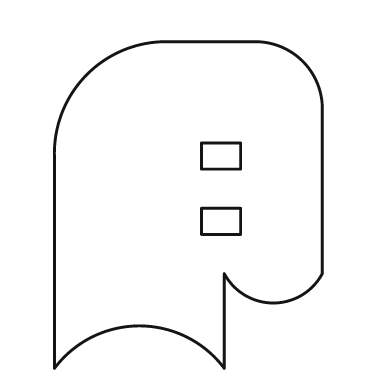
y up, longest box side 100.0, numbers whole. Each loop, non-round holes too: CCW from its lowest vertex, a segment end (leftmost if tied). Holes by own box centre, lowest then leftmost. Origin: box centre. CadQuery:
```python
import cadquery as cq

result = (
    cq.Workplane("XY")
    .moveTo(-41.0, -50.0)
    .threePointArc((-15.0, -37.0), (11.0, -50.0))
    .lineTo(11.0, -21.0)
    .threePointArc((26.0, -30.0), (41.0, -21.0))
    .lineTo(41.0, 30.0)
    .threePointArc((35.0, 44.0), (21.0, 50.0))
    .lineTo(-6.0, 50.0)
    .threePointArc((-31.0, 40.0), (-41.0, 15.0))
    .close()
    .moveTo(4.0, -9.0)
    .lineTo(16.0, -9.0)
    .lineTo(16.0, -1.0)
    .lineTo(4.0, -1.0)
    .close()
    .moveTo(4.0, 11.0)
    .lineTo(16.0, 11.0)
    .lineTo(16.0, 19.0)
    .lineTo(4.0, 19.0)
    .close()
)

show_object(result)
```